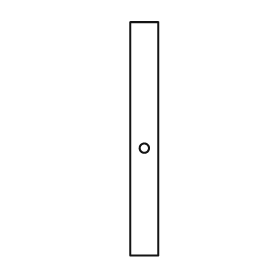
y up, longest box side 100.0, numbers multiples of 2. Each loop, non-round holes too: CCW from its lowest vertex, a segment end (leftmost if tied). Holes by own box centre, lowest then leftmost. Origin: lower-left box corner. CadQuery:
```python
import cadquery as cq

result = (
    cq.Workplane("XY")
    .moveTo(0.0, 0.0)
    .lineTo(12.0, 0.0)
    .lineTo(12.0, 100.0)
    .lineTo(0.0, 100.0)
    .close()
    .moveTo(6.0, 46.0)
    .circle(2.0)
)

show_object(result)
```